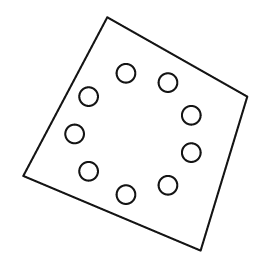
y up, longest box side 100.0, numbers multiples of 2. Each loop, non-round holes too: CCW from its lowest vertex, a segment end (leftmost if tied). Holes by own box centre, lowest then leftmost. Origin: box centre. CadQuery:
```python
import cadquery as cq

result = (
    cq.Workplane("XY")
    .moveTo(28.0, -50.0)
    .lineTo(48.0, 16.0)
    .lineTo(-12.0, 50.0)
    .lineTo(-48.0, -18.0)
    .close()
    .moveTo(-4.0, -26.0)
    .circle(4.0)
    .moveTo(14.0, -22.0)
    .circle(4.0)
    .moveTo(-20.0, -16.0)
    .circle(4.0)
    .moveTo(24.0, -8.0)
    .circle(4.0)
    .moveTo(-26.0, 0.0)
    .circle(4.0)
    .moveTo(24.0, 8.0)
    .circle(4.0)
    .moveTo(-20.0, 16.0)
    .circle(4.0)
    .moveTo(14.0, 22.0)
    .circle(4.0)
    .moveTo(-4.0, 26.0)
    .circle(4.0)
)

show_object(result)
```